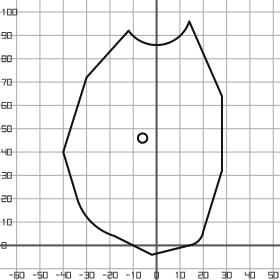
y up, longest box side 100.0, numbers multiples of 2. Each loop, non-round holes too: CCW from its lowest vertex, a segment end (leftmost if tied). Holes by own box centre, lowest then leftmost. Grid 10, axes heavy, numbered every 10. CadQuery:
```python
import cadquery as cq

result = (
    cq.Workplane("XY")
    .moveTo(-2.0, -4.0)
    .lineTo(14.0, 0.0)
    .threePointArc((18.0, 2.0), (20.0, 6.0))
    .lineTo(28.0, 32.0)
    .lineTo(28.0, 64.0)
    .lineTo(14.0, 96.0)
    .threePointArc((2.0, 86.0), (-12.0, 92.0))
    .lineTo(-30.0, 72.0)
    .lineTo(-40.0, 40.0)
    .lineTo(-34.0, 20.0)
    .threePointArc((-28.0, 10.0), (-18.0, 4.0))
    .close()
    .moveTo(-6.0, 46.0)
    .circle(2.0)
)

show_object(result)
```